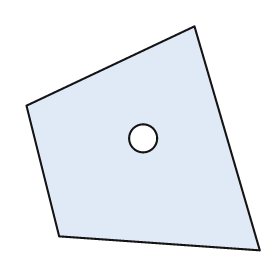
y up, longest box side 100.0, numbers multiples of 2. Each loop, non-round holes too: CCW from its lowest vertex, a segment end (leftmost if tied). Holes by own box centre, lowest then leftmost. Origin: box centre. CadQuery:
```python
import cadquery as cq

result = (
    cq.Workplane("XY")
    .moveTo(50.0, -48.0)
    .lineTo(22.0, 48.0)
    .lineTo(-50.0, 14.0)
    .lineTo(-36.0, -42.0)
    .close()
    .moveTo(0.0, 0.0)
    .circle(6.0)
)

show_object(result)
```